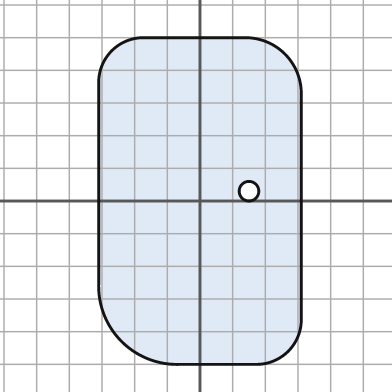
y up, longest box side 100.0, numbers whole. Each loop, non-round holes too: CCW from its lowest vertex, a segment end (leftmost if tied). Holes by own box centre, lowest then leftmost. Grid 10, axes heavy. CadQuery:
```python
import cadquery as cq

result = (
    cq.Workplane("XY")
    .moveTo(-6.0, -50.0)
    .lineTo(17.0, -50.0)
    .threePointArc((27.0, -46.0), (31.0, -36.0))
    .lineTo(31.0, 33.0)
    .threePointArc((26.0, 45.0), (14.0, 50.0))
    .lineTo(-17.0, 50.0)
    .threePointArc((-27.0, 46.0), (-31.0, 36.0))
    .lineTo(-31.0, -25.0)
    .threePointArc((-24.0, -43.0), (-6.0, -50.0))
    .close()
    .moveTo(15.0, 3.0)
    .circle(3.0)
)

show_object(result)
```